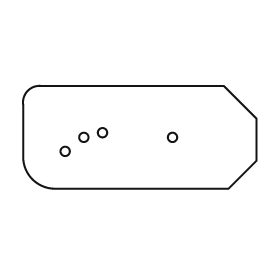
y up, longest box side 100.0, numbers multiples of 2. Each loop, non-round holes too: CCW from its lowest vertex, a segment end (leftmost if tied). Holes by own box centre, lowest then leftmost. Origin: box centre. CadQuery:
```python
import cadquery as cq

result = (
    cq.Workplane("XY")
    .moveTo(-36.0, -22.0)
    .lineTo(38.0, -22.0)
    .lineTo(50.0, -10.0)
    .lineTo(50.0, 8.0)
    .lineTo(36.0, 22.0)
    .lineTo(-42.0, 22.0)
    .threePointArc((-48.0, 20.0), (-50.0, 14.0))
    .lineTo(-50.0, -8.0)
    .threePointArc((-46.0, -18.0), (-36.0, -22.0))
    .close()
    .moveTo(-32.0, -6.0)
    .circle(2.0)
    .moveTo(-24.0, 0.0)
    .circle(2.0)
    .moveTo(14.0, 0.0)
    .circle(2.0)
    .moveTo(-16.0, 2.0)
    .circle(2.0)
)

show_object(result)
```